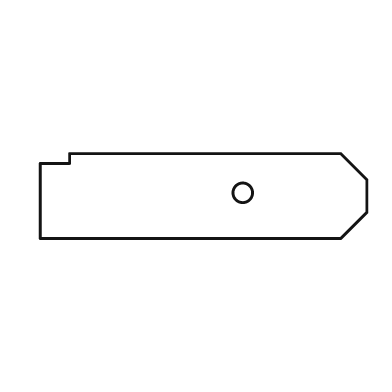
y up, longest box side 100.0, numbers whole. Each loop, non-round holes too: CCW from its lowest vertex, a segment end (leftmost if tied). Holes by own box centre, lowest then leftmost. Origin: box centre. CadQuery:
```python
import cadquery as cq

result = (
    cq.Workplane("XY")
    .moveTo(-50.0, -13.0)
    .lineTo(42.0, -13.0)
    .lineTo(50.0, -5.0)
    .lineTo(50.0, 5.0)
    .lineTo(42.0, 13.0)
    .lineTo(-41.0, 13.0)
    .lineTo(-41.0, 10.0)
    .lineTo(-50.0, 10.0)
    .close()
    .moveTo(12.0, 1.0)
    .circle(3.0)
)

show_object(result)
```